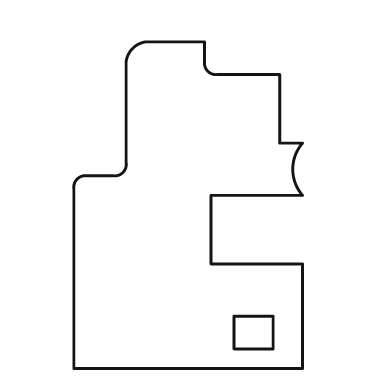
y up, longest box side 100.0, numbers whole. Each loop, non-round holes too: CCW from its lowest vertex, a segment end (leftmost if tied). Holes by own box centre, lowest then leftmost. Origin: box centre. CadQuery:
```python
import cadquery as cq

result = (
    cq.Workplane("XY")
    .moveTo(-35.0, -50.0)
    .lineTo(35.0, -50.0)
    .lineTo(35.0, -18.0)
    .lineTo(7.0, -18.0)
    .lineTo(7.0, 3.0)
    .lineTo(35.0, 3.0)
    .threePointArc((32.0, 11.0), (35.0, 19.0))
    .lineTo(28.0, 19.0)
    .lineTo(28.0, 40.0)
    .lineTo(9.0, 40.0)
    .threePointArc((6.0, 41.0), (5.0, 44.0))
    .lineTo(5.0, 50.0)
    .lineTo(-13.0, 50.0)
    .threePointArc((-17.0, 48.0), (-19.0, 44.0))
    .lineTo(-19.0, 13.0)
    .threePointArc((-20.0, 10.0), (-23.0, 9.0))
    .lineTo(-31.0, 9.0)
    .threePointArc((-34.0, 8.0), (-35.0, 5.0))
    .close()
    .moveTo(14.0, -44.0)
    .lineTo(26.0, -44.0)
    .lineTo(26.0, -34.0)
    .lineTo(14.0, -34.0)
    .close()
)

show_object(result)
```